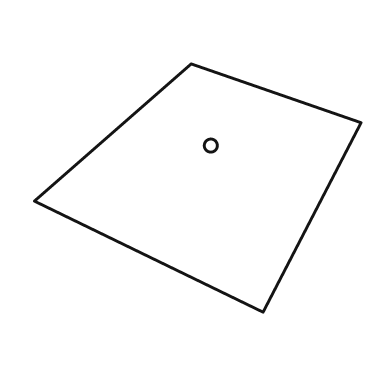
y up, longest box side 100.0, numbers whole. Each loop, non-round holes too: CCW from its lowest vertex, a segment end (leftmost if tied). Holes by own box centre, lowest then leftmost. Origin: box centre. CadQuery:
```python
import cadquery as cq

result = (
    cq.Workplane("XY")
    .moveTo(20.0, -38.0)
    .lineTo(50.0, 20.0)
    .lineTo(-2.0, 38.0)
    .lineTo(-50.0, -4.0)
    .close()
    .moveTo(4.0, 13.0)
    .circle(2.0)
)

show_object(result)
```